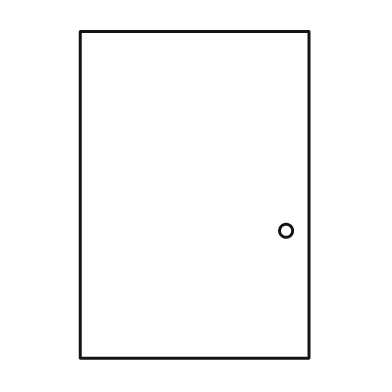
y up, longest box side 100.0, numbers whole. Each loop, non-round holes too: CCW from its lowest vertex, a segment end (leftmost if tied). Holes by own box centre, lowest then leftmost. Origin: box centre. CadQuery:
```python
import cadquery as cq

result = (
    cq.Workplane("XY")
    .moveTo(-35.0, -50.0)
    .lineTo(35.0, -50.0)
    .lineTo(35.0, 50.0)
    .lineTo(-35.0, 50.0)
    .close()
    .moveTo(28.0, -11.0)
    .circle(2.0)
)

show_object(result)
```